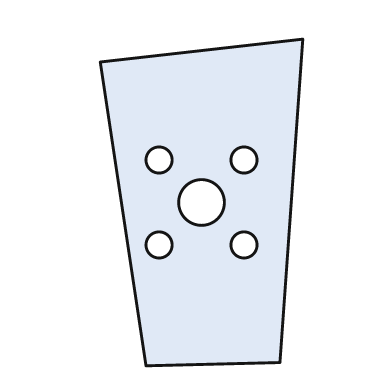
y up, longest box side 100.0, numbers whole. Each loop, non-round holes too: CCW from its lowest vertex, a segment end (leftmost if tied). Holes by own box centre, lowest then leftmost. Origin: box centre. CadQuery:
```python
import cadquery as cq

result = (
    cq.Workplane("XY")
    .moveTo(-17.0, -50.0)
    .lineTo(24.0, -49.0)
    .lineTo(31.0, 50.0)
    .lineTo(-31.0, 43.0)
    .close()
    .moveTo(-13.0, -13.0)
    .circle(4.0)
    .moveTo(13.0, -13.0)
    .circle(4.0)
    .moveTo(0.0, 0.0)
    .circle(7.0)
    .moveTo(-13.0, 13.0)
    .circle(4.0)
    .moveTo(13.0, 13.0)
    .circle(4.0)
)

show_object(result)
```